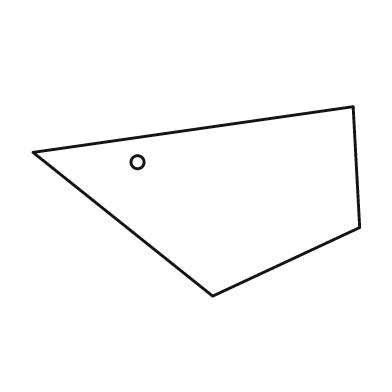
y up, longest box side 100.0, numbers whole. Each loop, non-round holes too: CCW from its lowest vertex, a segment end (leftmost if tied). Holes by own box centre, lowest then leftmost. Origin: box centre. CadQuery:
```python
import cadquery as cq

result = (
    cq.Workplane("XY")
    .moveTo(5.0, -29.0)
    .lineTo(50.0, -8.0)
    .lineTo(48.0, 29.0)
    .lineTo(-50.0, 15.0)
    .close()
    .moveTo(-18.0, 12.0)
    .circle(2.0)
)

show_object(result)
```